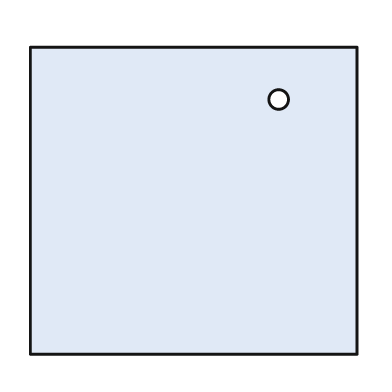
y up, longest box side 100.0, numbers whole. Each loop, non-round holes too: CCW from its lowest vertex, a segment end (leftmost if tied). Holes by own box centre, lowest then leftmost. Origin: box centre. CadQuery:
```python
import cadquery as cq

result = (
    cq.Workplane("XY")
    .moveTo(-50.0, -47.0)
    .lineTo(50.0, -47.0)
    .lineTo(50.0, 47.0)
    .lineTo(-50.0, 47.0)
    .close()
    .moveTo(26.0, 31.0)
    .circle(3.0)
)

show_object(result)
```